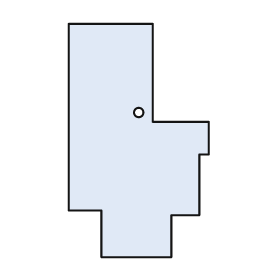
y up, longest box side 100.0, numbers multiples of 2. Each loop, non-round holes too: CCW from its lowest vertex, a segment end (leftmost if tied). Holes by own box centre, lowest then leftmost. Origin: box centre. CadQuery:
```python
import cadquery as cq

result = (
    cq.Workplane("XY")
    .moveTo(-16.0, -50.0)
    .lineTo(14.0, -50.0)
    .lineTo(14.0, -32.0)
    .lineTo(26.0, -32.0)
    .lineTo(26.0, -6.0)
    .lineTo(30.0, -6.0)
    .lineTo(30.0, 8.0)
    .lineTo(6.0, 8.0)
    .lineTo(6.0, 50.0)
    .lineTo(-30.0, 50.0)
    .lineTo(-30.0, -30.0)
    .lineTo(-16.0, -30.0)
    .close()
    .moveTo(0.0, 12.0)
    .circle(2.0)
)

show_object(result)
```